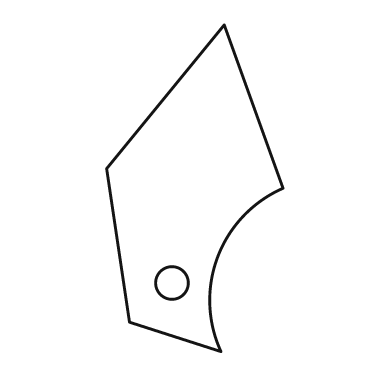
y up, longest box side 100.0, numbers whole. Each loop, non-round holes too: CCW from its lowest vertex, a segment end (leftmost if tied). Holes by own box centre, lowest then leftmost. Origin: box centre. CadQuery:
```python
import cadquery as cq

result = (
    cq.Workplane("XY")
    .moveTo(8.0, -50.0)
    .threePointArc((7.0, -21.0), (27.0, 0.0))
    .lineTo(9.0, 50.0)
    .lineTo(-27.0, 6.0)
    .lineTo(-20.0, -41.0)
    .close()
    .moveTo(-7.0, -29.0)
    .circle(5.0)
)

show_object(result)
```